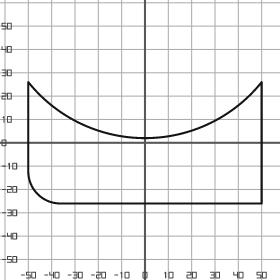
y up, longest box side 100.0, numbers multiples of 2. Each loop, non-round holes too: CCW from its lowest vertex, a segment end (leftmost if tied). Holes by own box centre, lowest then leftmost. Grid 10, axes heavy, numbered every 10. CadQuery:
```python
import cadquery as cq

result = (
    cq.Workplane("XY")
    .moveTo(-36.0, -26.0)
    .lineTo(50.0, -26.0)
    .lineTo(50.0, 26.0)
    .threePointArc((0.0, 2.0), (-50.0, 26.0))
    .lineTo(-50.0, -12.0)
    .threePointArc((-46.0, -22.0), (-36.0, -26.0))
    .close()
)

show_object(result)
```